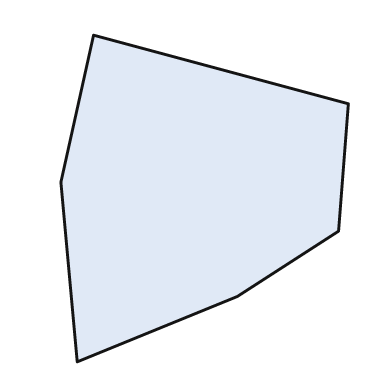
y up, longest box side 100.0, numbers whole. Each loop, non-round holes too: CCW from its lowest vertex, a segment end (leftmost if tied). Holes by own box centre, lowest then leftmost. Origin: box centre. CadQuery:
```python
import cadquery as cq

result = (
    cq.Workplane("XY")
    .moveTo(-39.0, -50.0)
    .lineTo(10.0, -30.0)
    .lineTo(41.0, -10.0)
    .lineTo(44.0, 29.0)
    .lineTo(-34.0, 50.0)
    .lineTo(-44.0, 5.0)
    .close()
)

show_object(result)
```